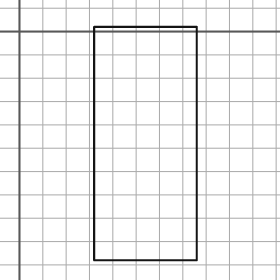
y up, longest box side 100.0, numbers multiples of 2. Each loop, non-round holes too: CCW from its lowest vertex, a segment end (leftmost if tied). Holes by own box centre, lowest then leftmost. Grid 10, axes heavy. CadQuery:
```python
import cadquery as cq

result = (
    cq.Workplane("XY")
    .moveTo(32.0, -98.0)
    .lineTo(76.0, -98.0)
    .lineTo(76.0, 2.0)
    .lineTo(32.0, 2.0)
    .close()
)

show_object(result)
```